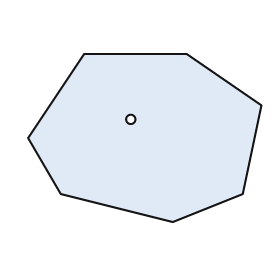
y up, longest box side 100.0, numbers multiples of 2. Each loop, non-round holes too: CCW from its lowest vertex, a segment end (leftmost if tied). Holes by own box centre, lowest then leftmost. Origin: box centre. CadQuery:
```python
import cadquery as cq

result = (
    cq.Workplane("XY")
    .moveTo(12.0, -36.0)
    .lineTo(42.0, -24.0)
    .lineTo(50.0, 14.0)
    .lineTo(18.0, 36.0)
    .lineTo(-26.0, 36.0)
    .lineTo(-50.0, 0.0)
    .lineTo(-36.0, -24.0)
    .close()
    .moveTo(-6.0, 8.0)
    .circle(2.0)
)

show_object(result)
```